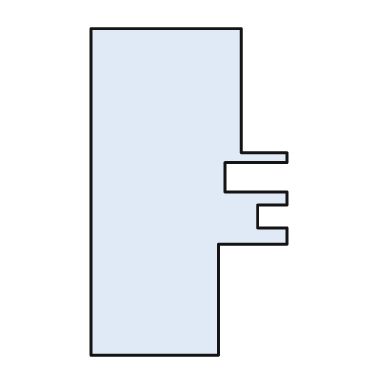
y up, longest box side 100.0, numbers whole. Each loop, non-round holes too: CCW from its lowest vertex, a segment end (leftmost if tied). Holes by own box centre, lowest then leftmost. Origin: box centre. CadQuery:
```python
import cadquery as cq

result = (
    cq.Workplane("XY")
    .moveTo(-30.0, -50.0)
    .lineTo(9.0, -50.0)
    .lineTo(9.0, -16.0)
    .lineTo(30.0, -16.0)
    .lineTo(30.0, -11.0)
    .lineTo(21.0, -11.0)
    .lineTo(21.0, -4.0)
    .lineTo(30.0, -4.0)
    .lineTo(30.0, 0.0)
    .lineTo(11.0, 0.0)
    .lineTo(11.0, 9.0)
    .lineTo(30.0, 9.0)
    .lineTo(30.0, 12.0)
    .lineTo(16.0, 12.0)
    .lineTo(16.0, 50.0)
    .lineTo(-30.0, 50.0)
    .close()
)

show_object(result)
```